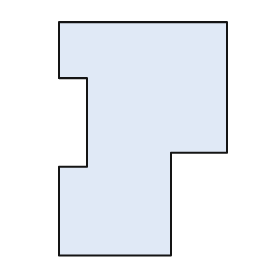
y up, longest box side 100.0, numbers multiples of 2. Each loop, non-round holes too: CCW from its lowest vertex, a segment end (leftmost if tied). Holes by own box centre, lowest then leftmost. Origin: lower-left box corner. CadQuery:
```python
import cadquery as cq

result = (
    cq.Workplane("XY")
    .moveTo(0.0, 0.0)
    .lineTo(48.0, 0.0)
    .lineTo(48.0, 44.0)
    .lineTo(72.0, 44.0)
    .lineTo(72.0, 100.0)
    .lineTo(0.0, 100.0)
    .lineTo(0.0, 76.0)
    .lineTo(12.0, 76.0)
    .lineTo(12.0, 38.0)
    .lineTo(0.0, 38.0)
    .close()
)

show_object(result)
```